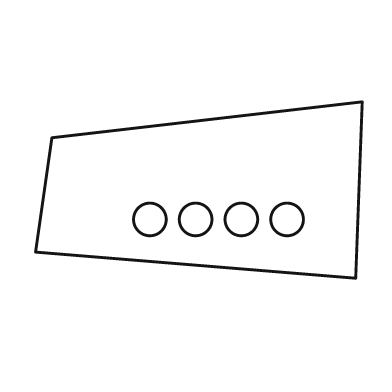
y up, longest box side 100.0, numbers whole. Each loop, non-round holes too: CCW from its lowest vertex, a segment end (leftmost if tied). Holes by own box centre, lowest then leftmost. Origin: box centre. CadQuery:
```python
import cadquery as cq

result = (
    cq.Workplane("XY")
    .moveTo(48.0, -27.0)
    .lineTo(50.0, 27.0)
    .lineTo(-45.0, 16.0)
    .lineTo(-50.0, -19.0)
    .close()
    .moveTo(-15.0, -9.0)
    .circle(5.0)
    .moveTo(-1.0, -9.0)
    .circle(5.0)
    .moveTo(13.0, -9.0)
    .circle(5.0)
    .moveTo(27.0, -9.0)
    .circle(5.0)
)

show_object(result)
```